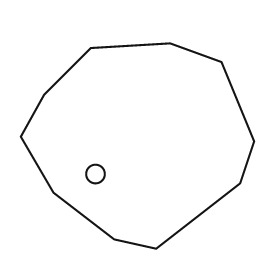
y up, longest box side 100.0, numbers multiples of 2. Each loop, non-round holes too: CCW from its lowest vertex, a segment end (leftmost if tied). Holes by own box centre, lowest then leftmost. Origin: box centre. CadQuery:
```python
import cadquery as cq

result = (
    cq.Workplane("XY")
    .moveTo(8.0, -44.0)
    .lineTo(44.0, -16.0)
    .lineTo(50.0, 2.0)
    .lineTo(36.0, 36.0)
    .lineTo(14.0, 44.0)
    .lineTo(-20.0, 42.0)
    .lineTo(-40.0, 22.0)
    .lineTo(-50.0, 4.0)
    .lineTo(-36.0, -20.0)
    .lineTo(-10.0, -40.0)
    .close()
    .moveTo(-18.0, -12.0)
    .circle(4.0)
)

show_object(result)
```